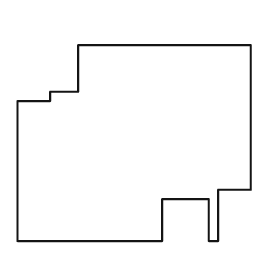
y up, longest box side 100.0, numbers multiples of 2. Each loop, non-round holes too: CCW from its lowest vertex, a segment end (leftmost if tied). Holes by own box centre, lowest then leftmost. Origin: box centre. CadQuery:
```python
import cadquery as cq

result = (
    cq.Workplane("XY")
    .moveTo(-50.0, -42.0)
    .lineTo(12.0, -42.0)
    .lineTo(12.0, -24.0)
    .lineTo(32.0, -24.0)
    .lineTo(32.0, -42.0)
    .lineTo(36.0, -42.0)
    .lineTo(36.0, -20.0)
    .lineTo(50.0, -20.0)
    .lineTo(50.0, 42.0)
    .lineTo(-24.0, 42.0)
    .lineTo(-24.0, 22.0)
    .lineTo(-36.0, 22.0)
    .lineTo(-36.0, 18.0)
    .lineTo(-50.0, 18.0)
    .close()
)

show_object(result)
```